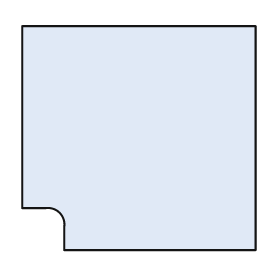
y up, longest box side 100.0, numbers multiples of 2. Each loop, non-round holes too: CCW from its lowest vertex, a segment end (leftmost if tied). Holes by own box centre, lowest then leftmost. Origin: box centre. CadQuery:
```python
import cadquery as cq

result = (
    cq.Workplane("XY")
    .moveTo(-32.0, -48.0)
    .lineTo(50.0, -48.0)
    .lineTo(50.0, 48.0)
    .lineTo(-50.0, 48.0)
    .lineTo(-50.0, -30.0)
    .lineTo(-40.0, -30.0)
    .threePointArc((-34.0, -32.0), (-32.0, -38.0))
    .close()
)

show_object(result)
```